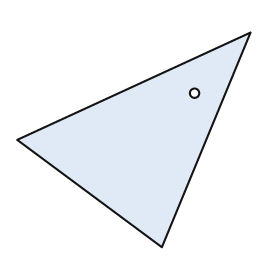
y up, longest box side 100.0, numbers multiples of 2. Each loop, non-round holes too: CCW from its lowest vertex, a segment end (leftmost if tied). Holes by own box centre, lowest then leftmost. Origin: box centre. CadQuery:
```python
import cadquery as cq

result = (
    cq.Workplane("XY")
    .moveTo(12.0, -46.0)
    .lineTo(50.0, 46.0)
    .lineTo(-50.0, 0.0)
    .close()
    .moveTo(26.0, 20.0)
    .circle(2.0)
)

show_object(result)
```